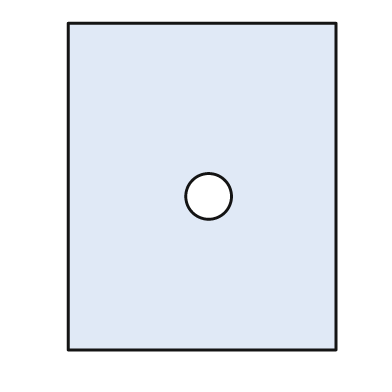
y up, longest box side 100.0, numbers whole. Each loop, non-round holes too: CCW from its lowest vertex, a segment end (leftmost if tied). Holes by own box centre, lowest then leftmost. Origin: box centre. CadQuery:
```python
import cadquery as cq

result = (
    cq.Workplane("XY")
    .moveTo(-41.0, -50.0)
    .lineTo(41.0, -50.0)
    .lineTo(41.0, 50.0)
    .lineTo(-41.0, 50.0)
    .close()
    .moveTo(2.0, -3.0)
    .circle(7.0)
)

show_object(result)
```